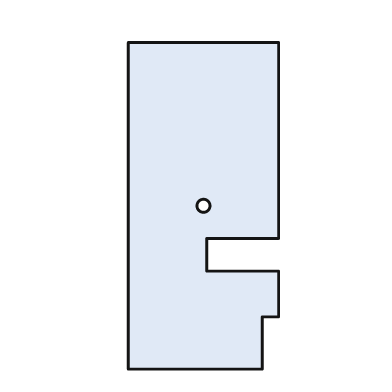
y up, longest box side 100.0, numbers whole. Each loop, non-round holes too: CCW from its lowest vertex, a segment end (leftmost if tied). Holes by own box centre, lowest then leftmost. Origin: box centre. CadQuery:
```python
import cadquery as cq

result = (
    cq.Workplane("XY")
    .moveTo(-23.0, -50.0)
    .lineTo(18.0, -50.0)
    .lineTo(18.0, -34.0)
    .lineTo(23.0, -34.0)
    .lineTo(23.0, -20.0)
    .lineTo(1.0, -20.0)
    .lineTo(1.0, -10.0)
    .lineTo(23.0, -10.0)
    .lineTo(23.0, 50.0)
    .lineTo(-23.0, 50.0)
    .close()
    .moveTo(0.0, 0.0)
    .circle(2.0)
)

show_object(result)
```